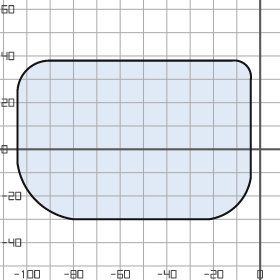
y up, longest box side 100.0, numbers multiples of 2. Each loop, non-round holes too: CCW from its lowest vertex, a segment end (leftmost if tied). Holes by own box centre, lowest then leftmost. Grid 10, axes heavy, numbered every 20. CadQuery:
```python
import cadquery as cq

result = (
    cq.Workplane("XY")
    .moveTo(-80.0, -30.0)
    .lineTo(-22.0, -30.0)
    .threePointArc((-10.0, -24.0), (-4.0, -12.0))
    .lineTo(-4.0, 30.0)
    .threePointArc((-6.0, 36.0), (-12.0, 38.0))
    .lineTo(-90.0, 38.0)
    .threePointArc((-100.0, 34.0), (-104.0, 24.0))
    .lineTo(-104.0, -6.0)
    .threePointArc((-96.0, -22.0), (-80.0, -30.0))
    .close()
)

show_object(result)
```